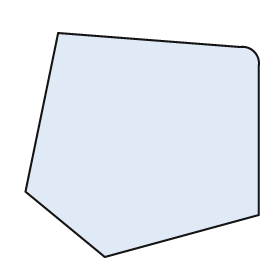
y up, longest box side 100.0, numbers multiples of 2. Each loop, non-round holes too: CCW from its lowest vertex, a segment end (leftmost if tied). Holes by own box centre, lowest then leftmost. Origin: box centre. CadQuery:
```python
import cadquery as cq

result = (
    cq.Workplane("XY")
    .moveTo(-16.0, -48.0)
    .lineTo(50.0, -30.0)
    .lineTo(50.0, 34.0)
    .threePointArc((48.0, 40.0), (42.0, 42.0))
    .lineTo(-36.0, 48.0)
    .lineTo(-50.0, -20.0)
    .close()
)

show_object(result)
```